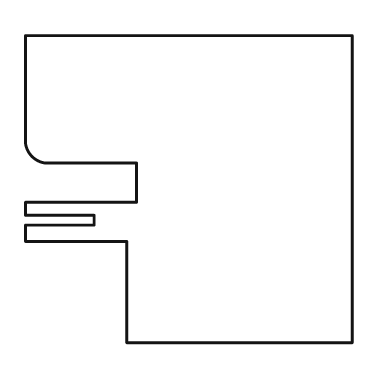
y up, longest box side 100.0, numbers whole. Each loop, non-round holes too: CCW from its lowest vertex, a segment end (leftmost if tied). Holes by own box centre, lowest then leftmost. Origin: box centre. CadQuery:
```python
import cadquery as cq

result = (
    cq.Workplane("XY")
    .moveTo(-19.0, -47.0)
    .lineTo(50.0, -47.0)
    .lineTo(50.0, 47.0)
    .lineTo(-50.0, 47.0)
    .lineTo(-50.0, 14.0)
    .threePointArc((-48.0, 10.0), (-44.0, 8.0))
    .lineTo(-16.0, 8.0)
    .lineTo(-16.0, -4.0)
    .lineTo(-50.0, -4.0)
    .lineTo(-50.0, -8.0)
    .lineTo(-29.0, -8.0)
    .lineTo(-29.0, -11.0)
    .lineTo(-50.0, -11.0)
    .lineTo(-50.0, -16.0)
    .lineTo(-19.0, -16.0)
    .close()
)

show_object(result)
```